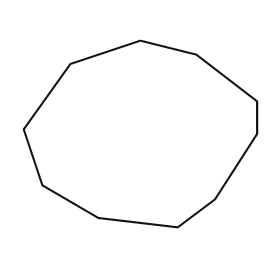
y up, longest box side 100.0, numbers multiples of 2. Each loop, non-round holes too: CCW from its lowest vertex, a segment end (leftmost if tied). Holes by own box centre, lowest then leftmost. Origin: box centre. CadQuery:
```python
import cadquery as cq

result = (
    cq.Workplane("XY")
    .moveTo(16.0, -40.0)
    .lineTo(32.0, -28.0)
    .lineTo(50.0, 0.0)
    .lineTo(50.0, 14.0)
    .lineTo(24.0, 34.0)
    .lineTo(0.0, 40.0)
    .lineTo(-30.0, 30.0)
    .lineTo(-50.0, 2.0)
    .lineTo(-42.0, -22.0)
    .lineTo(-18.0, -36.0)
    .close()
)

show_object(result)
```